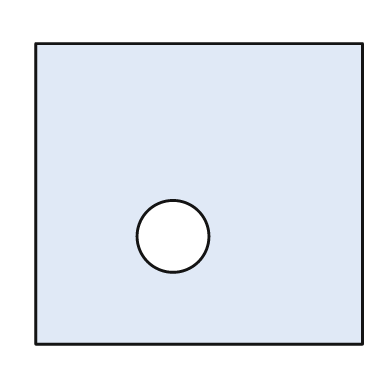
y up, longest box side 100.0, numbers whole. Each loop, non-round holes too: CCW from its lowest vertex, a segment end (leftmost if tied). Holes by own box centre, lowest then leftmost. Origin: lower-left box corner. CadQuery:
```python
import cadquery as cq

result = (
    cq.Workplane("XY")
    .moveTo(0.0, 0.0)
    .lineTo(100.0, 0.0)
    .lineTo(100.0, 92.0)
    .lineTo(0.0, 92.0)
    .close()
    .moveTo(42.0, 33.0)
    .circle(11.0)
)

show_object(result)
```